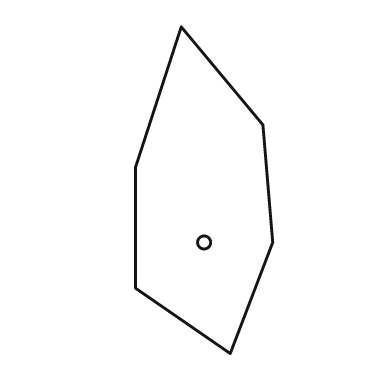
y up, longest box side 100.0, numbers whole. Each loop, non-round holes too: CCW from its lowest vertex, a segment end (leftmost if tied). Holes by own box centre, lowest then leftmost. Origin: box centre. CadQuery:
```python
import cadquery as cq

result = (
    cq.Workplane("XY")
    .moveTo(8.0, -50.0)
    .lineTo(21.0, -16.0)
    .lineTo(18.0, 20.0)
    .lineTo(-7.0, 50.0)
    .lineTo(-21.0, 7.0)
    .lineTo(-21.0, -30.0)
    .close()
    .moveTo(0.0, -16.0)
    .circle(2.0)
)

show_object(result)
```